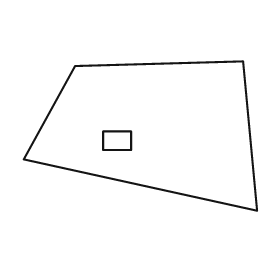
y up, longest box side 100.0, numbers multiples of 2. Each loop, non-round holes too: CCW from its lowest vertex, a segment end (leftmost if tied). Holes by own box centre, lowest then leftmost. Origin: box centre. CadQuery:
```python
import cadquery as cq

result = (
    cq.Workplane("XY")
    .moveTo(50.0, -32.0)
    .lineTo(44.0, 32.0)
    .lineTo(-28.0, 30.0)
    .lineTo(-50.0, -10.0)
    .close()
    .moveTo(-16.0, -6.0)
    .lineTo(-4.0, -6.0)
    .lineTo(-4.0, 2.0)
    .lineTo(-16.0, 2.0)
    .close()
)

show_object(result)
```